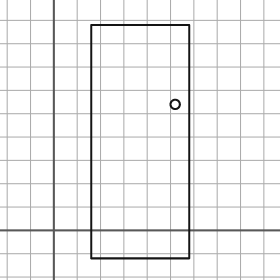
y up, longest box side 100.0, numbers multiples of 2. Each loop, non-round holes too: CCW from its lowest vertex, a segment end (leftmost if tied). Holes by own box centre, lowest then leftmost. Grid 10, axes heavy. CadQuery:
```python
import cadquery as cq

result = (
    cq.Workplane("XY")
    .moveTo(16.0, -12.0)
    .lineTo(58.0, -12.0)
    .lineTo(58.0, 88.0)
    .lineTo(16.0, 88.0)
    .close()
    .moveTo(52.0, 54.0)
    .circle(2.0)
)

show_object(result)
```